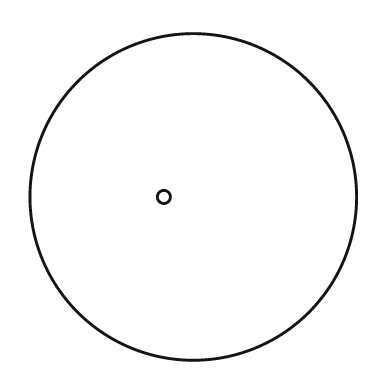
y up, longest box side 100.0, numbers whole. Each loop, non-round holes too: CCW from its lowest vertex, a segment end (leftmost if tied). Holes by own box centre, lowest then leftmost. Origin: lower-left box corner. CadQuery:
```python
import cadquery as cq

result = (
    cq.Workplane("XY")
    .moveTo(50.0, 50.0)
    .circle(50.0)
    .moveTo(41.0, 50.0)
    .circle(2.0)
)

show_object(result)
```